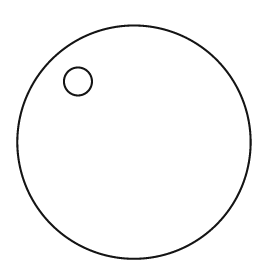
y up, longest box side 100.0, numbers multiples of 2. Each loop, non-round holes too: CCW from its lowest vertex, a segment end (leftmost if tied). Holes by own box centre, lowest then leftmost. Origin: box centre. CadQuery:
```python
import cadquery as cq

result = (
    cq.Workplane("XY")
    .moveTo(0.0, 0.0)
    .circle(50.0)
    .moveTo(-24.0, 26.0)
    .circle(6.0)
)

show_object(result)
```